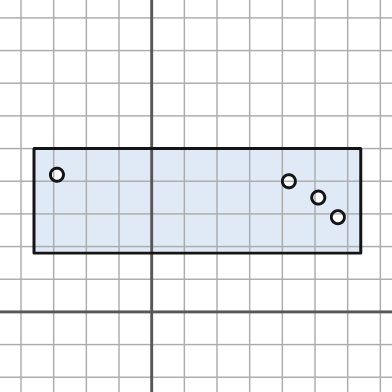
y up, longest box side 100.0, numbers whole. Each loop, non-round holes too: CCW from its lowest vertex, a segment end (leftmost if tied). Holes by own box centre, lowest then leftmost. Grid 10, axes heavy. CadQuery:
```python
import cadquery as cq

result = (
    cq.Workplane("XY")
    .moveTo(-36.0, 18.0)
    .lineTo(64.0, 18.0)
    .lineTo(64.0, 50.0)
    .lineTo(-36.0, 50.0)
    .close()
    .moveTo(57.0, 29.0)
    .circle(2.0)
    .moveTo(51.0, 35.0)
    .circle(2.0)
    .moveTo(42.0, 40.0)
    .circle(2.0)
    .moveTo(-29.0, 42.0)
    .circle(2.0)
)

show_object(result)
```